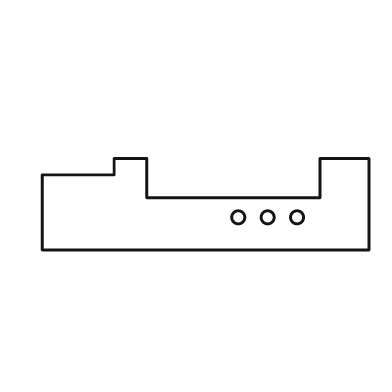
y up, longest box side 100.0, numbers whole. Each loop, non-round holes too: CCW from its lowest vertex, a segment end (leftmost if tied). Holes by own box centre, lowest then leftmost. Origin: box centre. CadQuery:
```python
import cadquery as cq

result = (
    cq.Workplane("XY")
    .moveTo(-50.0, -14.0)
    .lineTo(50.0, -14.0)
    .lineTo(50.0, 14.0)
    .lineTo(35.0, 14.0)
    .lineTo(35.0, 2.0)
    .lineTo(-18.0, 2.0)
    .lineTo(-18.0, 14.0)
    .lineTo(-28.0, 14.0)
    .lineTo(-28.0, 9.0)
    .lineTo(-50.0, 9.0)
    .close()
    .moveTo(10.0, -4.0)
    .circle(2.0)
    .moveTo(19.0, -4.0)
    .circle(2.0)
    .moveTo(28.0, -4.0)
    .circle(2.0)
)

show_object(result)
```